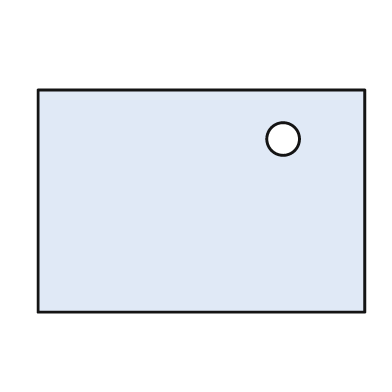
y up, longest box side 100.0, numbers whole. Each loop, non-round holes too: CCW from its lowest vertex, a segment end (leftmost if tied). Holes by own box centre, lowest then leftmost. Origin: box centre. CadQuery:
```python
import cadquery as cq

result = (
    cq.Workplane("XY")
    .moveTo(-50.0, -34.0)
    .lineTo(50.0, -34.0)
    .lineTo(50.0, 34.0)
    .lineTo(-50.0, 34.0)
    .close()
    .moveTo(25.0, 19.0)
    .circle(5.0)
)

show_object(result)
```